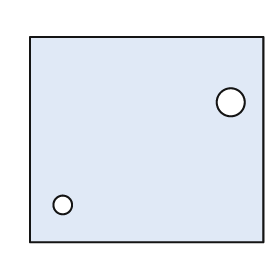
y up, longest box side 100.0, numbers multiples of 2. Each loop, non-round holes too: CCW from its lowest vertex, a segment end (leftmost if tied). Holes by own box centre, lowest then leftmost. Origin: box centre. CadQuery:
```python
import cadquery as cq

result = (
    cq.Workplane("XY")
    .moveTo(-50.0, -44.0)
    .lineTo(50.0, -44.0)
    .lineTo(50.0, 44.0)
    .lineTo(-50.0, 44.0)
    .close()
    .moveTo(-36.0, -28.0)
    .circle(4.0)
    .moveTo(36.0, 16.0)
    .circle(6.0)
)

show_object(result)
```